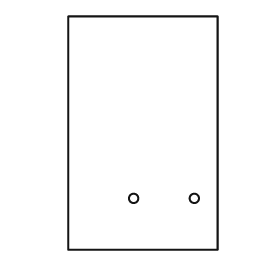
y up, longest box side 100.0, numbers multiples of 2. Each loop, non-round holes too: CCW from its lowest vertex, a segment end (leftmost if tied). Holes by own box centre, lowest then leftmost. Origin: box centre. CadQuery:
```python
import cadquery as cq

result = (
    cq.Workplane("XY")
    .moveTo(-32.0, -50.0)
    .lineTo(32.0, -50.0)
    .lineTo(32.0, 50.0)
    .lineTo(-32.0, 50.0)
    .close()
    .moveTo(-4.0, -28.0)
    .circle(2.0)
    .moveTo(22.0, -28.0)
    .circle(2.0)
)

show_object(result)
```